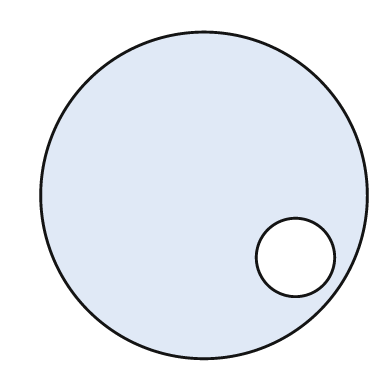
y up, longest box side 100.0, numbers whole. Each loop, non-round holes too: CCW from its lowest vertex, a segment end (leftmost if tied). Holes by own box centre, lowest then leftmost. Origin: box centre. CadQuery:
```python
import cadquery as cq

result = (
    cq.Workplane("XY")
    .moveTo(0.0, 0.0)
    .circle(50.0)
    .moveTo(28.0, -19.0)
    .circle(12.0)
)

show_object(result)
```